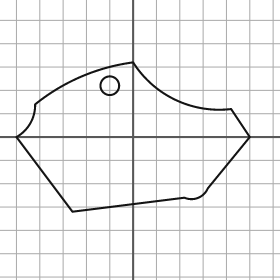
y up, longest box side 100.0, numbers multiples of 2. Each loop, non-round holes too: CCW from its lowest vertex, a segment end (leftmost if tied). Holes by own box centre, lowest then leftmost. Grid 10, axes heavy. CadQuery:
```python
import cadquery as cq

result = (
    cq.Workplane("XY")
    .moveTo(-26.0, -32.0)
    .lineTo(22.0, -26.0)
    .threePointArc((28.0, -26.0), (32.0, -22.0))
    .lineTo(50.0, 0.0)
    .lineTo(42.0, 12.0)
    .threePointArc((18.0, 16.0), (0.0, 32.0))
    .threePointArc((-22.0, 26.0), (-42.0, 14.0))
    .threePointArc((-44.0, 6.0), (-50.0, 0.0))
    .close()
    .moveTo(-10.0, 22.0)
    .circle(4.0)
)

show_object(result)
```